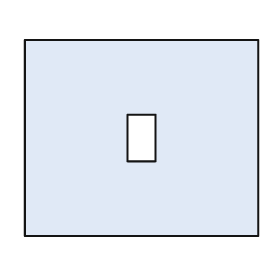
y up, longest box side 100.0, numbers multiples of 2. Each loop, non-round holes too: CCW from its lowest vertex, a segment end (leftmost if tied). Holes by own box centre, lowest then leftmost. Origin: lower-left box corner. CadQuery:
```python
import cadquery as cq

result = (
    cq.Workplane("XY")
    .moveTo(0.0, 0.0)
    .lineTo(100.0, 0.0)
    .lineTo(100.0, 84.0)
    .lineTo(0.0, 84.0)
    .close()
    .moveTo(44.0, 32.0)
    .lineTo(56.0, 32.0)
    .lineTo(56.0, 52.0)
    .lineTo(44.0, 52.0)
    .close()
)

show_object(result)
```